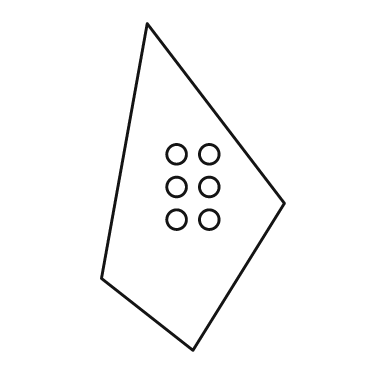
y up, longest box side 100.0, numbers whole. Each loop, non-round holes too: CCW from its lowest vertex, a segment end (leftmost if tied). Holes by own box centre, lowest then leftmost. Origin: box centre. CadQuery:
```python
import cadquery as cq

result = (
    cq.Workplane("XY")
    .moveTo(0.0, -50.0)
    .lineTo(28.0, -5.0)
    .lineTo(-14.0, 50.0)
    .lineTo(-28.0, -28.0)
    .close()
    .moveTo(-5.0, -10.0)
    .circle(3.0)
    .moveTo(5.0, -10.0)
    .circle(3.0)
    .moveTo(-5.0, 0.0)
    .circle(3.0)
    .moveTo(5.0, 0.0)
    .circle(3.0)
    .moveTo(-5.0, 10.0)
    .circle(3.0)
    .moveTo(5.0, 10.0)
    .circle(3.0)
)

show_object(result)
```